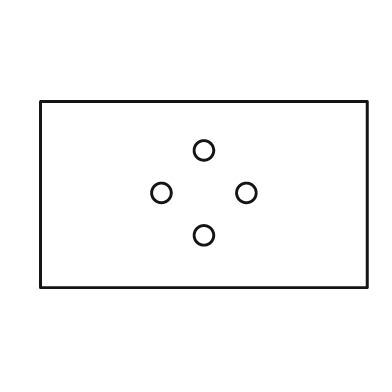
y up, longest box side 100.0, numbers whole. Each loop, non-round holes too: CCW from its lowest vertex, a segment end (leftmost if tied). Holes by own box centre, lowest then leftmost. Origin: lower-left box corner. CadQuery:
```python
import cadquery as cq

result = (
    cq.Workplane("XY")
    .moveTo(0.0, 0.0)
    .lineTo(100.0, 0.0)
    .lineTo(100.0, 57.0)
    .lineTo(0.0, 57.0)
    .close()
    .moveTo(50.0, 16.0)
    .circle(3.0)
    .moveTo(37.0, 29.0)
    .circle(3.0)
    .moveTo(63.0, 29.0)
    .circle(3.0)
    .moveTo(50.0, 42.0)
    .circle(3.0)
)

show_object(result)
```